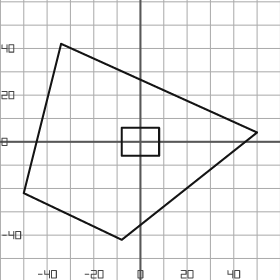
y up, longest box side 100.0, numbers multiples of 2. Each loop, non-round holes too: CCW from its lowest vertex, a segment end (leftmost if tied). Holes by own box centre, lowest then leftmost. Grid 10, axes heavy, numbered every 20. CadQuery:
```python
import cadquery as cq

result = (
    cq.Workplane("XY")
    .moveTo(-8.0, -42.0)
    .lineTo(50.0, 4.0)
    .lineTo(-34.0, 42.0)
    .lineTo(-50.0, -22.0)
    .close()
    .moveTo(-8.0, -6.0)
    .lineTo(8.0, -6.0)
    .lineTo(8.0, 6.0)
    .lineTo(-8.0, 6.0)
    .close()
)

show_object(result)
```